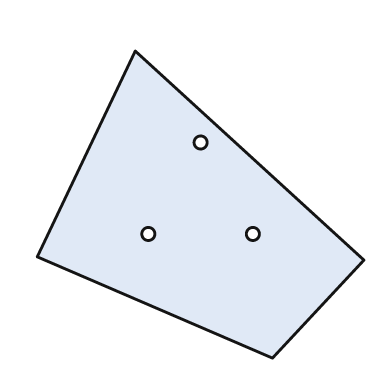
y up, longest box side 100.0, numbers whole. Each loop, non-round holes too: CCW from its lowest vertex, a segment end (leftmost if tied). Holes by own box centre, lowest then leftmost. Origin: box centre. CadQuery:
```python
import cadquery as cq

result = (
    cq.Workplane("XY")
    .moveTo(22.0, -47.0)
    .lineTo(50.0, -17.0)
    .lineTo(-20.0, 47.0)
    .lineTo(-50.0, -16.0)
    .close()
    .moveTo(-16.0, -9.0)
    .circle(2.0)
    .moveTo(16.0, -9.0)
    .circle(2.0)
    .moveTo(0.0, 19.0)
    .circle(2.0)
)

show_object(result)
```